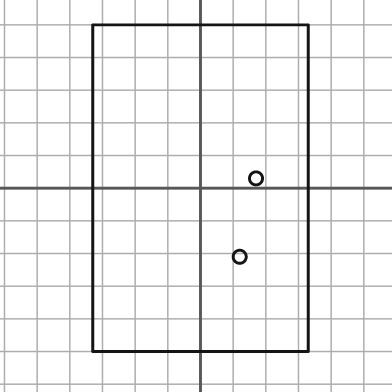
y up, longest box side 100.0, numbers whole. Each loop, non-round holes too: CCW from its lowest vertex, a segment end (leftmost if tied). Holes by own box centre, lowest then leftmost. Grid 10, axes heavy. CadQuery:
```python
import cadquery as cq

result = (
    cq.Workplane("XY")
    .moveTo(-33.0, -50.0)
    .lineTo(33.0, -50.0)
    .lineTo(33.0, 50.0)
    .lineTo(-33.0, 50.0)
    .close()
    .moveTo(12.0, -21.0)
    .circle(2.0)
    .moveTo(17.0, 3.0)
    .circle(2.0)
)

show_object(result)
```